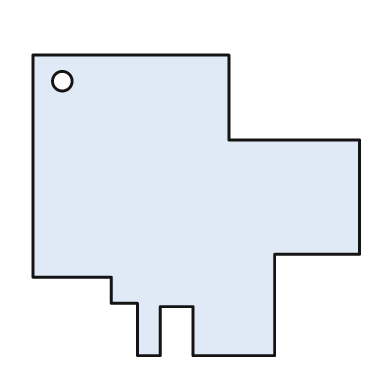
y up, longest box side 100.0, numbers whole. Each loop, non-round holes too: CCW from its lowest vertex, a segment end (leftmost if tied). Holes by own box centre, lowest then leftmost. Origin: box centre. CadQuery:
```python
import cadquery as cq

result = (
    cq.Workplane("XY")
    .moveTo(-18.0, -46.0)
    .lineTo(-11.0, -46.0)
    .lineTo(-11.0, -31.0)
    .lineTo(-1.0, -31.0)
    .lineTo(-1.0, -46.0)
    .lineTo(24.0, -46.0)
    .lineTo(24.0, -15.0)
    .lineTo(50.0, -15.0)
    .lineTo(50.0, 20.0)
    .lineTo(10.0, 20.0)
    .lineTo(10.0, 46.0)
    .lineTo(-50.0, 46.0)
    .lineTo(-50.0, -22.0)
    .lineTo(-26.0, -22.0)
    .lineTo(-26.0, -30.0)
    .lineTo(-18.0, -30.0)
    .close()
    .moveTo(-41.0, 38.0)
    .circle(3.0)
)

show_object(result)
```